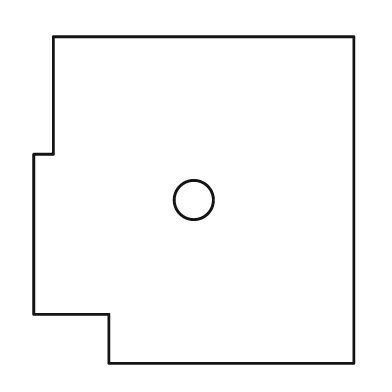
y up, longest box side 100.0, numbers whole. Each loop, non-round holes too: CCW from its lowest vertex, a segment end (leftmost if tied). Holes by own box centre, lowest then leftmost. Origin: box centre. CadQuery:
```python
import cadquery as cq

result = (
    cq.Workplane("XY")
    .moveTo(-26.0, -50.0)
    .lineTo(49.0, -50.0)
    .lineTo(49.0, 50.0)
    .lineTo(-43.0, 50.0)
    .lineTo(-43.0, 14.0)
    .lineTo(-49.0, 14.0)
    .lineTo(-49.0, -35.0)
    .lineTo(-26.0, -35.0)
    .close()
    .moveTo(0.0, 0.0)
    .circle(6.0)
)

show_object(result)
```